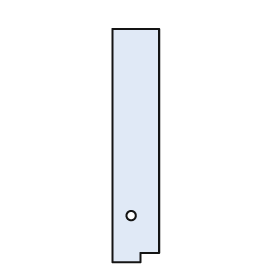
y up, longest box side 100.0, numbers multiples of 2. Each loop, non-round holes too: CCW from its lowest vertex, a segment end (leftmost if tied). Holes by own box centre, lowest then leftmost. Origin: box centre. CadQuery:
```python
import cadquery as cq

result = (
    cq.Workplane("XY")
    .moveTo(-10.0, -50.0)
    .lineTo(2.0, -50.0)
    .lineTo(2.0, -46.0)
    .lineTo(10.0, -46.0)
    .lineTo(10.0, 50.0)
    .lineTo(-10.0, 50.0)
    .close()
    .moveTo(-2.0, -30.0)
    .circle(2.0)
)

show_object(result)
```